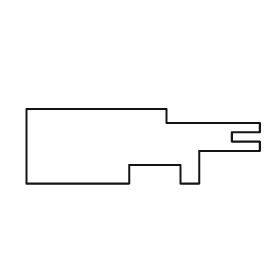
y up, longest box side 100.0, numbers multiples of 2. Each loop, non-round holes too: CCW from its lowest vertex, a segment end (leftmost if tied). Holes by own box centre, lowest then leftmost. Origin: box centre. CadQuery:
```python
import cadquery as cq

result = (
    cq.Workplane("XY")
    .moveTo(-50.0, -16.0)
    .lineTo(-6.0, -16.0)
    .lineTo(-6.0, -8.0)
    .lineTo(16.0, -8.0)
    .lineTo(16.0, -16.0)
    .lineTo(24.0, -16.0)
    .lineTo(24.0, -2.0)
    .lineTo(50.0, -2.0)
    .lineTo(50.0, 2.0)
    .lineTo(38.0, 2.0)
    .lineTo(38.0, 6.0)
    .lineTo(50.0, 6.0)
    .lineTo(50.0, 10.0)
    .lineTo(10.0, 10.0)
    .lineTo(10.0, 16.0)
    .lineTo(-50.0, 16.0)
    .close()
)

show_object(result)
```